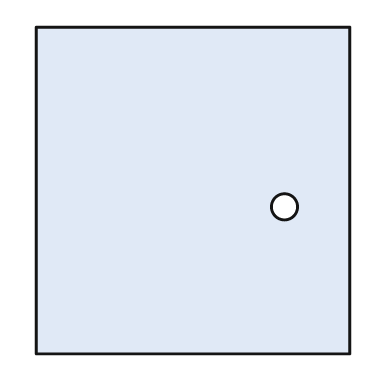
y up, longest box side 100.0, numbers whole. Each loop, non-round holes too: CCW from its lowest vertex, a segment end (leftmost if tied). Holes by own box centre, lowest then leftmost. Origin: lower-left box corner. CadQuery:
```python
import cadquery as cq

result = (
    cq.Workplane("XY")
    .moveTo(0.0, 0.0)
    .lineTo(96.0, 0.0)
    .lineTo(96.0, 100.0)
    .lineTo(0.0, 100.0)
    .close()
    .moveTo(76.0, 45.0)
    .circle(4.0)
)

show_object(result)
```